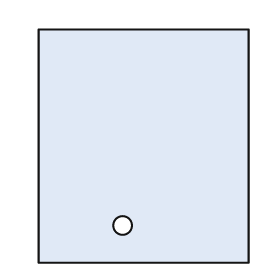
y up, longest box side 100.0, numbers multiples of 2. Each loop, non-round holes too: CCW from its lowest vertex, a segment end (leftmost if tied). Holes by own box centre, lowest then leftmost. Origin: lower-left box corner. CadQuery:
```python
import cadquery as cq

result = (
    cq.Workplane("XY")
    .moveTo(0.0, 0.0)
    .lineTo(90.0, 0.0)
    .lineTo(90.0, 100.0)
    .lineTo(0.0, 100.0)
    .close()
    .moveTo(36.0, 16.0)
    .circle(4.0)
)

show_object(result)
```